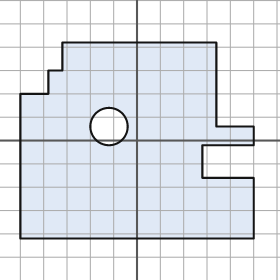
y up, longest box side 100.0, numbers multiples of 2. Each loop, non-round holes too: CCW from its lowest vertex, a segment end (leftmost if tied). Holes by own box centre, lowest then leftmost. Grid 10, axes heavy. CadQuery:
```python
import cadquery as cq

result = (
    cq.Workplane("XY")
    .moveTo(-50.0, -42.0)
    .lineTo(50.0, -42.0)
    .lineTo(50.0, -16.0)
    .lineTo(28.0, -16.0)
    .lineTo(28.0, -2.0)
    .lineTo(50.0, -2.0)
    .lineTo(50.0, 6.0)
    .lineTo(34.0, 6.0)
    .lineTo(34.0, 42.0)
    .lineTo(-32.0, 42.0)
    .lineTo(-32.0, 30.0)
    .lineTo(-38.0, 30.0)
    .lineTo(-38.0, 20.0)
    .lineTo(-50.0, 20.0)
    .close()
    .moveTo(-12.0, 6.0)
    .circle(8.0)
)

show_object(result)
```